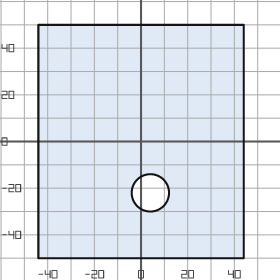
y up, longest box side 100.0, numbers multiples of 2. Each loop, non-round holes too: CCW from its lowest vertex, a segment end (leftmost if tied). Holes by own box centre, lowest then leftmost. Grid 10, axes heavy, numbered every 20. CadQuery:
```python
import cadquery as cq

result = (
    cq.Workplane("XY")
    .moveTo(-44.0, -50.0)
    .lineTo(44.0, -50.0)
    .lineTo(44.0, 50.0)
    .lineTo(-44.0, 50.0)
    .close()
    .moveTo(4.0, -22.0)
    .circle(8.0)
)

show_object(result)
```